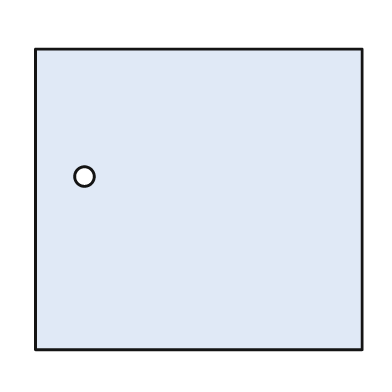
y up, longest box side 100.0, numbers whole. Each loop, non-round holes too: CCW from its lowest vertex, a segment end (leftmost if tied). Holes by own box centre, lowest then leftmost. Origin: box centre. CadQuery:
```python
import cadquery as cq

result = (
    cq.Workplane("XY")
    .moveTo(-50.0, -46.0)
    .lineTo(50.0, -46.0)
    .lineTo(50.0, 46.0)
    .lineTo(-50.0, 46.0)
    .close()
    .moveTo(-35.0, 7.0)
    .circle(3.0)
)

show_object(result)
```